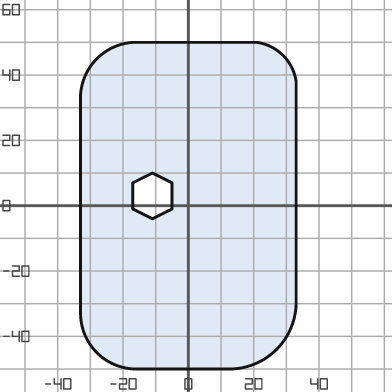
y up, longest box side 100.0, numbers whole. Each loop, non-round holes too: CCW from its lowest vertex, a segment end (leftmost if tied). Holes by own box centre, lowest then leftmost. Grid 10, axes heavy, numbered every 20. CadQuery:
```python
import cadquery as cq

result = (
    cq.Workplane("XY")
    .moveTo(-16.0, -50.0)
    .lineTo(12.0, -50.0)
    .threePointArc((27.0, -44.0), (33.0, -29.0))
    .lineTo(33.0, 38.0)
    .threePointArc((29.0, 46.0), (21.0, 50.0))
    .lineTo(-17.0, 50.0)
    .threePointArc((-28.0, 45.0), (-33.0, 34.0))
    .lineTo(-33.0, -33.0)
    .threePointArc((-28.0, -45.0), (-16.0, -50.0))
    .close()
    .moveTo(-11.0, -4.0)
    .lineTo(-5.0, -1.0)
    .lineTo(-5.0, 7.0)
    .lineTo(-11.0, 10.0)
    .lineTo(-17.0, 7.0)
    .lineTo(-17.0, -1.0)
    .close()
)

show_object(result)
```